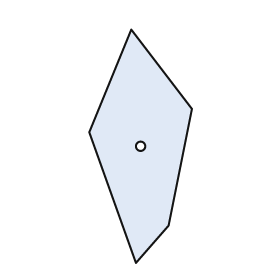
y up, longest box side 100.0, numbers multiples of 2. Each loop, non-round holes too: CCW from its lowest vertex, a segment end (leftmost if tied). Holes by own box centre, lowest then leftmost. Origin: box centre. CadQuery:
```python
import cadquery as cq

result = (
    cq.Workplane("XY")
    .moveTo(-2.0, -50.0)
    .lineTo(12.0, -34.0)
    .lineTo(22.0, 16.0)
    .lineTo(-4.0, 50.0)
    .lineTo(-22.0, 6.0)
    .close()
    .moveTo(0.0, 0.0)
    .circle(2.0)
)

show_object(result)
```